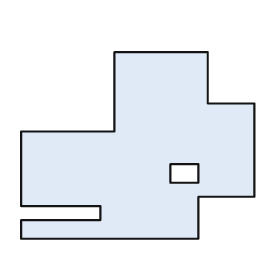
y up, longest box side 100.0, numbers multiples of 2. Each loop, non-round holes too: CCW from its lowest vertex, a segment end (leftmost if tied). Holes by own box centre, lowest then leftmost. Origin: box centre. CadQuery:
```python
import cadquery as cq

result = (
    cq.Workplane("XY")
    .moveTo(-50.0, -40.0)
    .lineTo(26.0, -40.0)
    .lineTo(26.0, -22.0)
    .lineTo(50.0, -22.0)
    .lineTo(50.0, 18.0)
    .lineTo(30.0, 18.0)
    .lineTo(30.0, 40.0)
    .lineTo(-10.0, 40.0)
    .lineTo(-10.0, 6.0)
    .lineTo(-50.0, 6.0)
    .lineTo(-50.0, -26.0)
    .lineTo(-16.0, -26.0)
    .lineTo(-16.0, -32.0)
    .lineTo(-50.0, -32.0)
    .close()
    .moveTo(14.0, -16.0)
    .lineTo(26.0, -16.0)
    .lineTo(26.0, -8.0)
    .lineTo(14.0, -8.0)
    .close()
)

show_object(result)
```